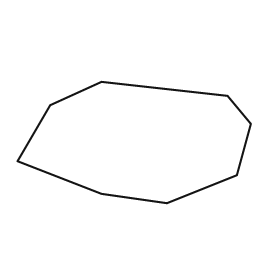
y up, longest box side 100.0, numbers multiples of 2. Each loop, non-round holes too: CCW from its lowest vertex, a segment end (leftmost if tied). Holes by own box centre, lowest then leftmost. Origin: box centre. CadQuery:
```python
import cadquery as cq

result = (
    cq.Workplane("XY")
    .moveTo(14.0, -26.0)
    .lineTo(44.0, -14.0)
    .lineTo(50.0, 8.0)
    .lineTo(40.0, 20.0)
    .lineTo(-14.0, 26.0)
    .lineTo(-36.0, 16.0)
    .lineTo(-50.0, -8.0)
    .lineTo(-14.0, -22.0)
    .close()
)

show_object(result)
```